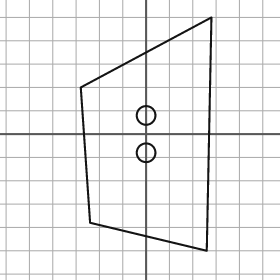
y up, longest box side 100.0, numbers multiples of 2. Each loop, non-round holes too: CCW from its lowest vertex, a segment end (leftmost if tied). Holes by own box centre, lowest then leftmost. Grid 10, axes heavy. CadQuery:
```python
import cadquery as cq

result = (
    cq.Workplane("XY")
    .moveTo(26.0, -50.0)
    .lineTo(28.0, 50.0)
    .lineTo(-28.0, 20.0)
    .lineTo(-24.0, -38.0)
    .close()
    .moveTo(0.0, -8.0)
    .circle(4.0)
    .moveTo(0.0, 8.0)
    .circle(4.0)
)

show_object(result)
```